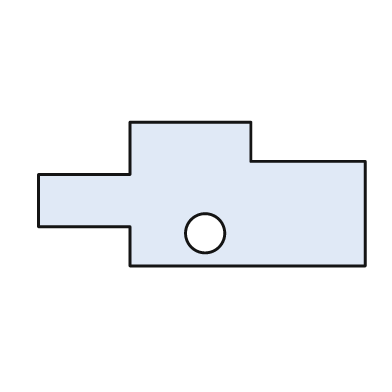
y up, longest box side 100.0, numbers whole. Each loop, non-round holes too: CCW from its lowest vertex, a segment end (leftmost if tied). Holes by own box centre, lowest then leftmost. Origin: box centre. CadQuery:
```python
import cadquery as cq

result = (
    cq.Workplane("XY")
    .moveTo(-22.0, -22.0)
    .lineTo(50.0, -22.0)
    .lineTo(50.0, 10.0)
    .lineTo(15.0, 10.0)
    .lineTo(15.0, 22.0)
    .lineTo(-22.0, 22.0)
    .lineTo(-22.0, 6.0)
    .lineTo(-50.0, 6.0)
    .lineTo(-50.0, -10.0)
    .lineTo(-22.0, -10.0)
    .close()
    .moveTo(1.0, -12.0)
    .circle(6.0)
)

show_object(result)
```